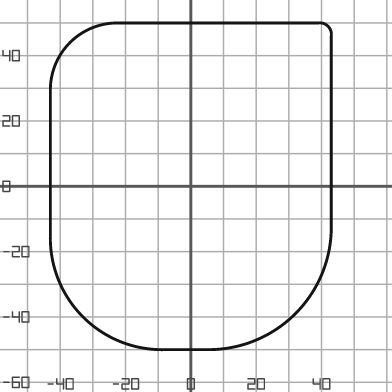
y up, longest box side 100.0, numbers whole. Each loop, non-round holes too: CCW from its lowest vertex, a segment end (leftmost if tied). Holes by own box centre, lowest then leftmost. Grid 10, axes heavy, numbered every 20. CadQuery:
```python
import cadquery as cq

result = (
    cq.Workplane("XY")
    .moveTo(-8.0, -50.0)
    .lineTo(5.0, -50.0)
    .threePointArc((32.0, -39.0), (43.0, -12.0))
    .lineTo(43.0, 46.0)
    .threePointArc((42.0, 49.0), (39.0, 50.0))
    .lineTo(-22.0, 50.0)
    .threePointArc((-37.0, 44.0), (-43.0, 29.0))
    .lineTo(-43.0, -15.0)
    .threePointArc((-33.0, -40.0), (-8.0, -50.0))
    .close()
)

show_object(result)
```